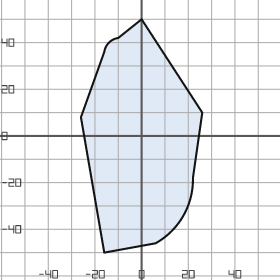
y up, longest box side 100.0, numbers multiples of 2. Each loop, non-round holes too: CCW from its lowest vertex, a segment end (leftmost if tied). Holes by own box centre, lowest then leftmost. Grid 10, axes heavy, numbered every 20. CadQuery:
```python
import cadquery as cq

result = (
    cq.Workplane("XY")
    .moveTo(-16.0, -50.0)
    .lineTo(6.0, -46.0)
    .threePointArc((18.0, -34.0), (22.0, -18.0))
    .lineTo(26.0, 10.0)
    .lineTo(0.0, 50.0)
    .lineTo(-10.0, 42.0)
    .threePointArc((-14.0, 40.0), (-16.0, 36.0))
    .lineTo(-26.0, 8.0)
    .close()
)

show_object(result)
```